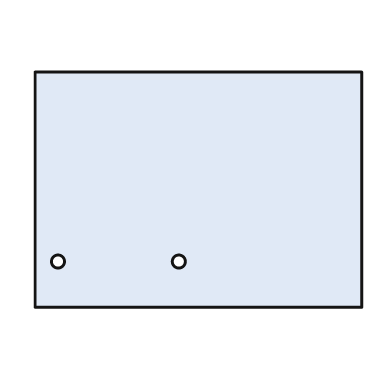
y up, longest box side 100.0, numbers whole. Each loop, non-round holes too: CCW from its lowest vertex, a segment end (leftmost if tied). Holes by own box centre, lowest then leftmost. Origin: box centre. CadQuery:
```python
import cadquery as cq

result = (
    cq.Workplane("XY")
    .moveTo(-50.0, -36.0)
    .lineTo(50.0, -36.0)
    .lineTo(50.0, 36.0)
    .lineTo(-50.0, 36.0)
    .close()
    .moveTo(-43.0, -22.0)
    .circle(2.0)
    .moveTo(-6.0, -22.0)
    .circle(2.0)
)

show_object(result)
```